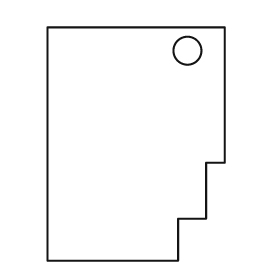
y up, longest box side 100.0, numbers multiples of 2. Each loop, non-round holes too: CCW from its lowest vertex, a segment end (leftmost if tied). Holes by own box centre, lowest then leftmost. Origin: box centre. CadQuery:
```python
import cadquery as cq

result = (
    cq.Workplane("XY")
    .moveTo(-38.0, -50.0)
    .lineTo(18.0, -50.0)
    .lineTo(18.0, -32.0)
    .lineTo(30.0, -32.0)
    .lineTo(30.0, -8.0)
    .lineTo(38.0, -8.0)
    .lineTo(38.0, 50.0)
    .lineTo(-38.0, 50.0)
    .close()
    .moveTo(22.0, 40.0)
    .circle(6.0)
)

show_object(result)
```